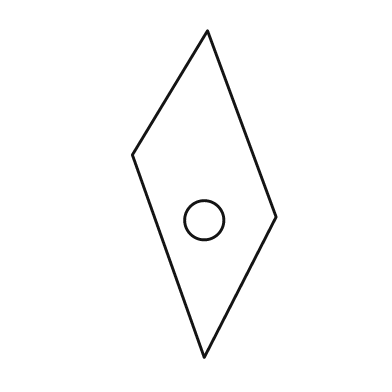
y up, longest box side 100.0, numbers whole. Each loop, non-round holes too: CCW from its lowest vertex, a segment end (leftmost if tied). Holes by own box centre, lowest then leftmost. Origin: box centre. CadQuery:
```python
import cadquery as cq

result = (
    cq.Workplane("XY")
    .moveTo(0.0, -50.0)
    .lineTo(22.0, -7.0)
    .lineTo(1.0, 50.0)
    .lineTo(-22.0, 12.0)
    .close()
    .moveTo(0.0, -8.0)
    .circle(6.0)
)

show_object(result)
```